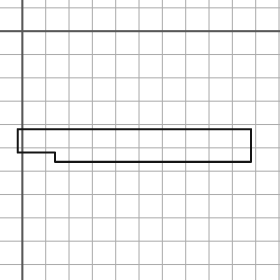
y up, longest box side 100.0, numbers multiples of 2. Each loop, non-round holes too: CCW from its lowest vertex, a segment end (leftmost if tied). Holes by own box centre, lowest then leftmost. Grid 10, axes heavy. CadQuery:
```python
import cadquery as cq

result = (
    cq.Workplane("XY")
    .moveTo(14.0, -56.0)
    .lineTo(98.0, -56.0)
    .lineTo(98.0, -42.0)
    .lineTo(-2.0, -42.0)
    .lineTo(-2.0, -52.0)
    .lineTo(14.0, -52.0)
    .close()
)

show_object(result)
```